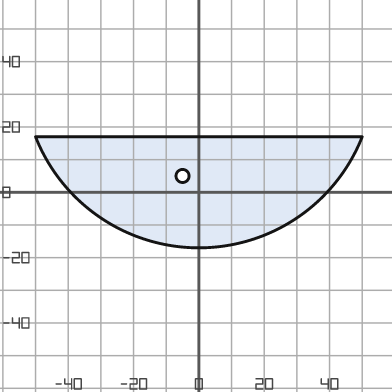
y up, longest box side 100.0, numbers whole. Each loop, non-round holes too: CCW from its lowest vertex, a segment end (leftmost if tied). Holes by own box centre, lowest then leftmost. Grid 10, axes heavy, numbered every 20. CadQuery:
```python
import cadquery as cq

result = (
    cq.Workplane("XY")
    .moveTo(-50.0, 17.0)
    .threePointArc((0.0, -17.0), (50.0, 17.0))
    .close()
    .moveTo(-5.0, 5.0)
    .circle(2.0)
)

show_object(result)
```